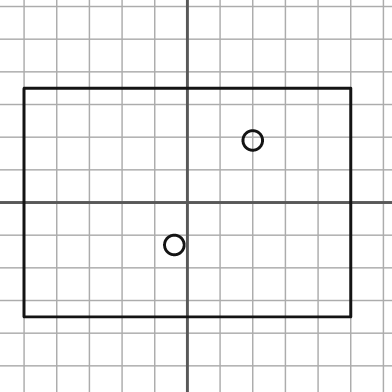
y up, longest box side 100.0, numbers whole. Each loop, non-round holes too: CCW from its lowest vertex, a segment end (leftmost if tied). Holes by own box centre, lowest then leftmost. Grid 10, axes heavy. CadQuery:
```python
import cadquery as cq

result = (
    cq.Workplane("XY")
    .moveTo(-50.0, -35.0)
    .lineTo(50.0, -35.0)
    .lineTo(50.0, 35.0)
    .lineTo(-50.0, 35.0)
    .close()
    .moveTo(-4.0, -13.0)
    .circle(3.0)
    .moveTo(20.0, 19.0)
    .circle(3.0)
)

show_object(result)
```